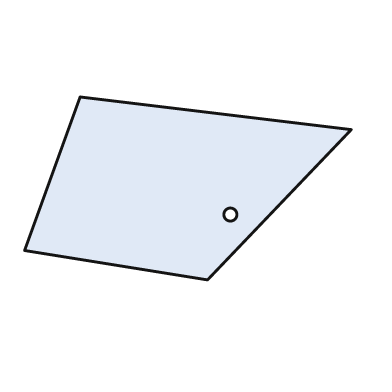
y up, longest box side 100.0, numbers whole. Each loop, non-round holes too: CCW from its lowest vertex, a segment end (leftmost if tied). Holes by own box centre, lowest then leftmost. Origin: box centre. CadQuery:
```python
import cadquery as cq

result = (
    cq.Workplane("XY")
    .moveTo(6.0, -28.0)
    .lineTo(50.0, 18.0)
    .lineTo(-33.0, 28.0)
    .lineTo(-50.0, -19.0)
    .close()
    .moveTo(13.0, -8.0)
    .circle(2.0)
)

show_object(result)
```